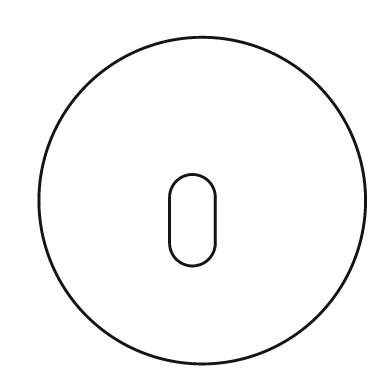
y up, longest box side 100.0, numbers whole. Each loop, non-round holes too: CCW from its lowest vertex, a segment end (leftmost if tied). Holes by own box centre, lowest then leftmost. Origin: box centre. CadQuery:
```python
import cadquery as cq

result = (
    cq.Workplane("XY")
    .moveTo(0.0, 0.0)
    .circle(50.0)
    .moveTo(-10.0, -13.0)
    .threePointArc((-3.0, -20.0), (4.0, -13.0))
    .lineTo(4.0, 1.0)
    .threePointArc((-3.0, 8.0), (-10.0, 1.0))
    .close()
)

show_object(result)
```